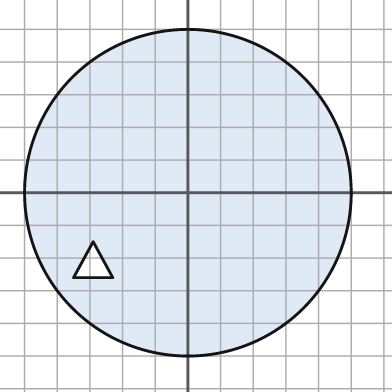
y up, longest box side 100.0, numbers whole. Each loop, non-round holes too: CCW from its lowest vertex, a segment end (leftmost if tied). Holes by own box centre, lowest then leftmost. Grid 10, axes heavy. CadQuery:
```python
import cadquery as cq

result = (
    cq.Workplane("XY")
    .moveTo(0.0, 0.0)
    .circle(50.0)
    .moveTo(-35.0, -26.0)
    .lineTo(-23.0, -26.0)
    .lineTo(-29.0, -15.0)
    .close()
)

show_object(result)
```